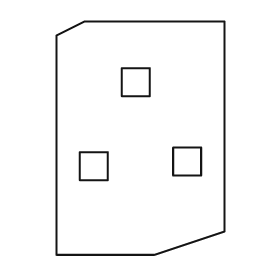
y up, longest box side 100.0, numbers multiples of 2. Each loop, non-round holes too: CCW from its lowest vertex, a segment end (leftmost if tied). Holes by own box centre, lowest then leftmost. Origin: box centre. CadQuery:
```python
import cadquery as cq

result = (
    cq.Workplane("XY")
    .moveTo(-36.0, -50.0)
    .lineTo(6.0, -50.0)
    .lineTo(36.0, -40.0)
    .lineTo(36.0, 50.0)
    .lineTo(-24.0, 50.0)
    .lineTo(-36.0, 44.0)
    .close()
    .moveTo(-26.0, -18.0)
    .lineTo(-14.0, -18.0)
    .lineTo(-14.0, -6.0)
    .lineTo(-26.0, -6.0)
    .close()
    .moveTo(14.0, -16.0)
    .lineTo(26.0, -16.0)
    .lineTo(26.0, -4.0)
    .lineTo(14.0, -4.0)
    .close()
    .moveTo(-8.0, 18.0)
    .lineTo(4.0, 18.0)
    .lineTo(4.0, 30.0)
    .lineTo(-8.0, 30.0)
    .close()
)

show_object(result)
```